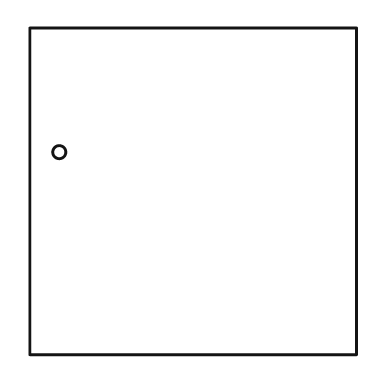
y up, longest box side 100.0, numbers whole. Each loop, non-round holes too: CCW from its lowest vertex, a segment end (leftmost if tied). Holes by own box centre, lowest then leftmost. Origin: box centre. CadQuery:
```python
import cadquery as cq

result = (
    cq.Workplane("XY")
    .moveTo(-50.0, -50.0)
    .lineTo(50.0, -50.0)
    .lineTo(50.0, 50.0)
    .lineTo(-50.0, 50.0)
    .close()
    .moveTo(-41.0, 12.0)
    .circle(2.0)
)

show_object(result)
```